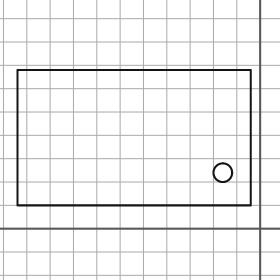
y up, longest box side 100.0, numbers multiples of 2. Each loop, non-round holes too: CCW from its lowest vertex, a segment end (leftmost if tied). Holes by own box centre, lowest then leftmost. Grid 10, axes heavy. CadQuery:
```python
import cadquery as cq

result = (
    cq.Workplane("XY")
    .moveTo(-104.0, 10.0)
    .lineTo(-4.0, 10.0)
    .lineTo(-4.0, 68.0)
    .lineTo(-104.0, 68.0)
    .close()
    .moveTo(-16.0, 24.0)
    .circle(4.0)
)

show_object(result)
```